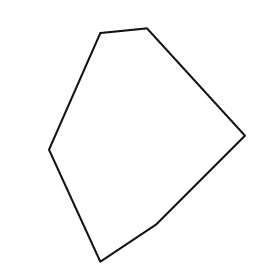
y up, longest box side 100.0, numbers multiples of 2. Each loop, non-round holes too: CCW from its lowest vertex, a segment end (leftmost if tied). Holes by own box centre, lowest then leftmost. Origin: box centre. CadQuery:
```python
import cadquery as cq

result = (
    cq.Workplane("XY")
    .moveTo(-20.0, -50.0)
    .lineTo(4.0, -34.0)
    .lineTo(42.0, 4.0)
    .lineTo(0.0, 50.0)
    .lineTo(-20.0, 48.0)
    .lineTo(-42.0, -2.0)
    .close()
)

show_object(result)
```